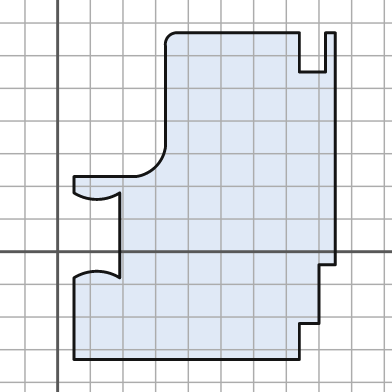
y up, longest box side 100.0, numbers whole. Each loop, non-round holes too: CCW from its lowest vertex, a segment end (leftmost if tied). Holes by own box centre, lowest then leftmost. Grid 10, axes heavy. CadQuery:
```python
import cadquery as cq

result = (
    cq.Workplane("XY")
    .moveTo(5.0, -33.0)
    .lineTo(74.0, -33.0)
    .lineTo(74.0, -22.0)
    .lineTo(80.0, -22.0)
    .lineTo(80.0, -4.0)
    .lineTo(85.0, -4.0)
    .lineTo(85.0, 67.0)
    .lineTo(82.0, 67.0)
    .lineTo(82.0, 55.0)
    .lineTo(74.0, 55.0)
    .lineTo(74.0, 67.0)
    .lineTo(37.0, 67.0)
    .threePointArc((34.0, 66.0), (33.0, 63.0))
    .lineTo(33.0, 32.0)
    .threePointArc((30.0, 26.0), (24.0, 23.0))
    .lineTo(5.0, 23.0)
    .lineTo(5.0, 18.0)
    .threePointArc((12.0, 16.0), (19.0, 18.0))
    .lineTo(19.0, -8.0)
    .threePointArc((12.0, -6.0), (5.0, -8.0))
    .close()
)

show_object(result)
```